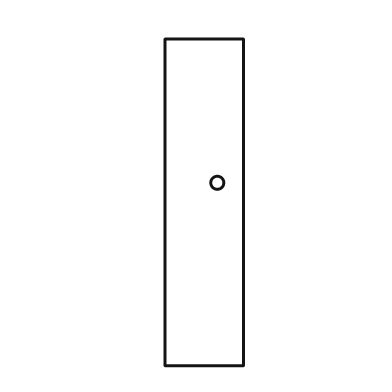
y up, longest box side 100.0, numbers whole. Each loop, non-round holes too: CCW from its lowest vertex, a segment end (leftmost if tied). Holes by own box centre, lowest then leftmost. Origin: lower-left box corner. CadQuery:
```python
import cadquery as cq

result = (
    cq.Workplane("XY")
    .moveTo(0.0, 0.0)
    .lineTo(24.0, 0.0)
    .lineTo(24.0, 100.0)
    .lineTo(0.0, 100.0)
    .close()
    .moveTo(16.0, 56.0)
    .circle(2.0)
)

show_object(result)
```